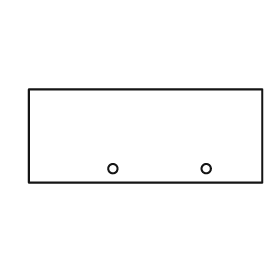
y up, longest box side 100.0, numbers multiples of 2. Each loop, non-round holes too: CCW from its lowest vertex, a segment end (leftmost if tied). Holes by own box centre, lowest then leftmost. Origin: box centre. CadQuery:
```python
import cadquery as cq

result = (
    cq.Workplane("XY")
    .moveTo(-50.0, -20.0)
    .lineTo(50.0, -20.0)
    .lineTo(50.0, 20.0)
    .lineTo(-50.0, 20.0)
    .close()
    .moveTo(-14.0, -14.0)
    .circle(2.0)
    .moveTo(26.0, -14.0)
    .circle(2.0)
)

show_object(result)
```